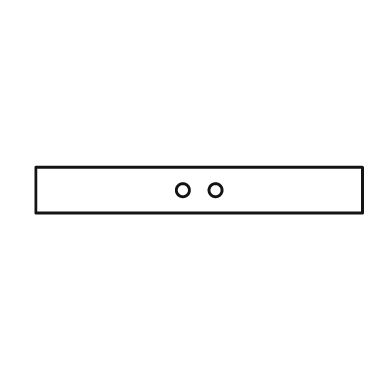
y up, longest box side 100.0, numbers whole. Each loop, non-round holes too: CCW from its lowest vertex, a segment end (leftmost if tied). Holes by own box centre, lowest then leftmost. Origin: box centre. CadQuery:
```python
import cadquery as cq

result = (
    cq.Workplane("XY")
    .moveTo(-50.0, -7.0)
    .lineTo(50.0, -7.0)
    .lineTo(50.0, 7.0)
    .lineTo(-50.0, 7.0)
    .close()
    .moveTo(-5.0, 0.0)
    .circle(2.0)
    .moveTo(5.0, 0.0)
    .circle(2.0)
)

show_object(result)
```